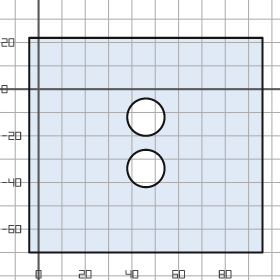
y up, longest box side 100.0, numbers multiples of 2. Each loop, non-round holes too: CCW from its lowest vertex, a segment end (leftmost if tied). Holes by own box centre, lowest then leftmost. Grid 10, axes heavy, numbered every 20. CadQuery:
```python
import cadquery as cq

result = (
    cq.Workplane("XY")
    .moveTo(-4.0, -70.0)
    .lineTo(96.0, -70.0)
    .lineTo(96.0, 22.0)
    .lineTo(-4.0, 22.0)
    .close()
    .moveTo(46.0, -34.0)
    .circle(8.0)
    .moveTo(46.0, -12.0)
    .circle(8.0)
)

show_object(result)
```